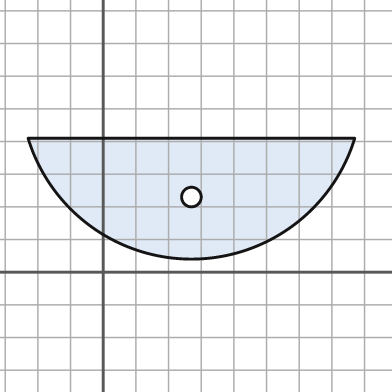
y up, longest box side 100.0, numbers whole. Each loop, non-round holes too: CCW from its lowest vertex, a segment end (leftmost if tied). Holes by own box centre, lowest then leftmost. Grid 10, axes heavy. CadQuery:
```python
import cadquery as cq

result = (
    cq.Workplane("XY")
    .moveTo(-23.0, 41.0)
    .threePointArc((27.0, 4.0), (77.0, 41.0))
    .close()
    .moveTo(27.0, 23.0)
    .circle(3.0)
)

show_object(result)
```